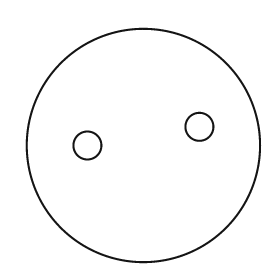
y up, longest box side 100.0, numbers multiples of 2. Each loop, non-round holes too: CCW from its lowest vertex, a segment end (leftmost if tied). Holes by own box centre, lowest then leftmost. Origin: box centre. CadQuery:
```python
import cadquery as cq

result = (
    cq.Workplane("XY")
    .moveTo(0.0, 0.0)
    .circle(50.0)
    .moveTo(-24.0, 0.0)
    .circle(6.0)
    .moveTo(24.0, 8.0)
    .circle(6.0)
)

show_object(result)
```